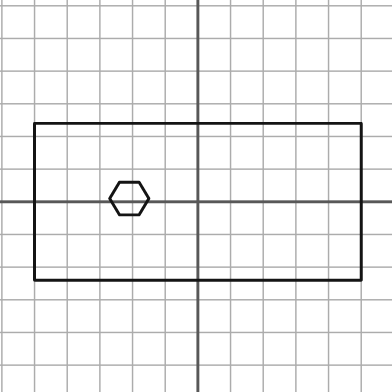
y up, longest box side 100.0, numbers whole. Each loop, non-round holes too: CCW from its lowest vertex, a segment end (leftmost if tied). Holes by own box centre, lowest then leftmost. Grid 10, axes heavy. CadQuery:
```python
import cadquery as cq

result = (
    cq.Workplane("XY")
    .moveTo(-50.0, -24.0)
    .lineTo(50.0, -24.0)
    .lineTo(50.0, 24.0)
    .lineTo(-50.0, 24.0)
    .close()
    .moveTo(-24.0, -4.0)
    .lineTo(-18.0, -4.0)
    .lineTo(-15.0, 1.0)
    .lineTo(-18.0, 6.0)
    .lineTo(-24.0, 6.0)
    .lineTo(-27.0, 1.0)
    .close()
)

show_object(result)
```